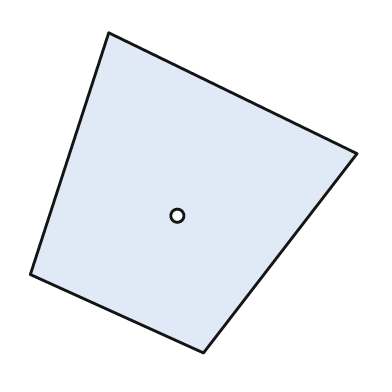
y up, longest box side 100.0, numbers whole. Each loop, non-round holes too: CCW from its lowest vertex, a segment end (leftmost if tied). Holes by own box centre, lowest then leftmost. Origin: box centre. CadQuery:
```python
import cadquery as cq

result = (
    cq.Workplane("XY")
    .moveTo(3.0, -49.0)
    .lineTo(50.0, 12.0)
    .lineTo(-26.0, 49.0)
    .lineTo(-50.0, -25.0)
    .close()
    .moveTo(-5.0, -7.0)
    .circle(2.0)
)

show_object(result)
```